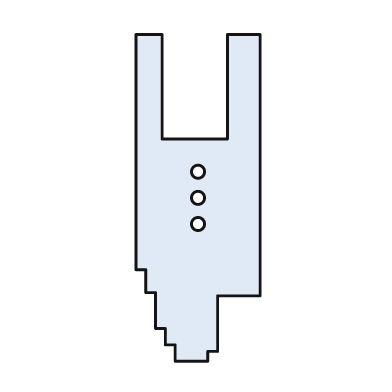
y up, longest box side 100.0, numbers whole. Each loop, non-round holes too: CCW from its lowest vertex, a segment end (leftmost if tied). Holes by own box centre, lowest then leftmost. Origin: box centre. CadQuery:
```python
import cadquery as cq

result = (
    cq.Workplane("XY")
    .moveTo(-7.0, -50.0)
    .lineTo(3.0, -50.0)
    .lineTo(3.0, -47.0)
    .lineTo(6.0, -47.0)
    .lineTo(6.0, -30.0)
    .lineTo(19.0, -30.0)
    .lineTo(19.0, 50.0)
    .lineTo(9.0, 50.0)
    .lineTo(9.0, 18.0)
    .lineTo(-11.0, 18.0)
    .lineTo(-11.0, 50.0)
    .lineTo(-19.0, 50.0)
    .lineTo(-19.0, -22.0)
    .lineTo(-16.0, -22.0)
    .lineTo(-16.0, -29.0)
    .lineTo(-13.0, -29.0)
    .lineTo(-13.0, -40.0)
    .lineTo(-10.0, -40.0)
    .lineTo(-10.0, -45.0)
    .lineTo(-7.0, -45.0)
    .close()
    .moveTo(0.0, -8.0)
    .circle(2.0)
    .moveTo(0.0, 0.0)
    .circle(2.0)
    .moveTo(0.0, 8.0)
    .circle(2.0)
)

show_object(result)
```